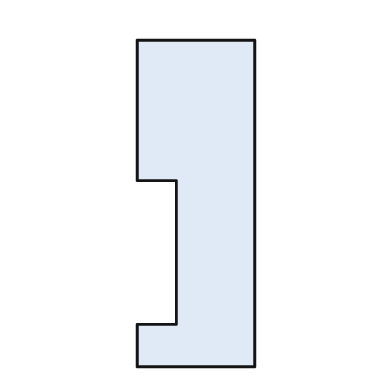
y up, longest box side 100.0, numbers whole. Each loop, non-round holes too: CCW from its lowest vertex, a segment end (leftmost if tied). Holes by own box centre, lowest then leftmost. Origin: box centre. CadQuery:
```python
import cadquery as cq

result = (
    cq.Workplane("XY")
    .moveTo(-18.0, -50.0)
    .lineTo(18.0, -50.0)
    .lineTo(18.0, 50.0)
    .lineTo(-18.0, 50.0)
    .lineTo(-18.0, 7.0)
    .lineTo(-6.0, 7.0)
    .lineTo(-6.0, -37.0)
    .lineTo(-18.0, -37.0)
    .close()
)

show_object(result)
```